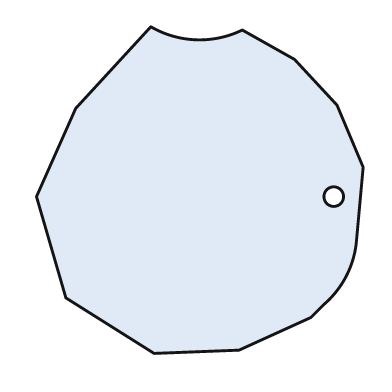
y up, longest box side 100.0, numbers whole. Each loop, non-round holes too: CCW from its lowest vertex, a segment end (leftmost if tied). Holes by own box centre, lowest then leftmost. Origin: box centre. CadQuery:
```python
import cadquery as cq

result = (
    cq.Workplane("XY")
    .moveTo(-14.0, -50.0)
    .lineTo(12.0, -49.0)
    .lineTo(34.0, -39.0)
    .lineTo(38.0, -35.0)
    .threePointArc((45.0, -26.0), (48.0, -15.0))
    .lineTo(50.0, 7.0)
    .lineTo(42.0, 26.0)
    .lineTo(29.0, 40.0)
    .lineTo(13.0, 49.0)
    .threePointArc((-1.0, 46.0), (-15.0, 50.0))
    .lineTo(-38.0, 25.0)
    .lineTo(-50.0, -2.0)
    .lineTo(-41.0, -33.0)
    .close()
    .moveTo(41.0, -2.0)
    .circle(3.0)
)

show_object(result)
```